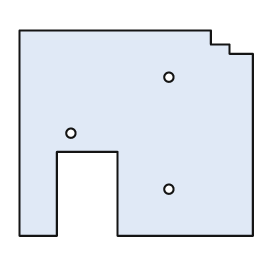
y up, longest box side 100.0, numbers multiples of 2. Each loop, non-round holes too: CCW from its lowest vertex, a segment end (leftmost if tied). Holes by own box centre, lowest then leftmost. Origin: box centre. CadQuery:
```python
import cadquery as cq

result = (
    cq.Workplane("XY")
    .moveTo(-50.0, -44.0)
    .lineTo(-34.0, -44.0)
    .lineTo(-34.0, -8.0)
    .lineTo(-8.0, -8.0)
    .lineTo(-8.0, -44.0)
    .lineTo(50.0, -44.0)
    .lineTo(50.0, 34.0)
    .lineTo(40.0, 34.0)
    .lineTo(40.0, 38.0)
    .lineTo(32.0, 38.0)
    .lineTo(32.0, 44.0)
    .lineTo(-50.0, 44.0)
    .close()
    .moveTo(14.0, -24.0)
    .circle(2.0)
    .moveTo(-28.0, 0.0)
    .circle(2.0)
    .moveTo(14.0, 24.0)
    .circle(2.0)
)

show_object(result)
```